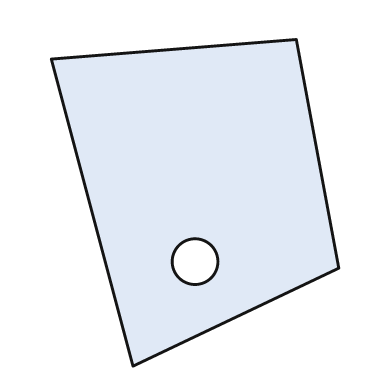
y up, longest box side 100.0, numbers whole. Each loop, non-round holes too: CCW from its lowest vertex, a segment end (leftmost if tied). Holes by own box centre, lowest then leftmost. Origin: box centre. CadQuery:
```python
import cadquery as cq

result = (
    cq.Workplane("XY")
    .moveTo(-19.0, -50.0)
    .lineTo(44.0, -20.0)
    .lineTo(31.0, 50.0)
    .lineTo(-44.0, 44.0)
    .close()
    .moveTo(0.0, -18.0)
    .circle(7.0)
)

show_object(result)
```